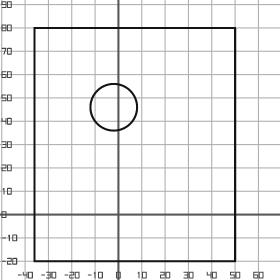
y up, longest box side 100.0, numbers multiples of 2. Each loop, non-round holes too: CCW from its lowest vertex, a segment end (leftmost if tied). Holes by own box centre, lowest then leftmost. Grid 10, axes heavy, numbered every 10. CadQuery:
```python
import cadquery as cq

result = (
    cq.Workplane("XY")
    .moveTo(-36.0, -20.0)
    .lineTo(50.0, -20.0)
    .lineTo(50.0, 80.0)
    .lineTo(-36.0, 80.0)
    .close()
    .moveTo(-2.0, 46.0)
    .circle(10.0)
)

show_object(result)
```